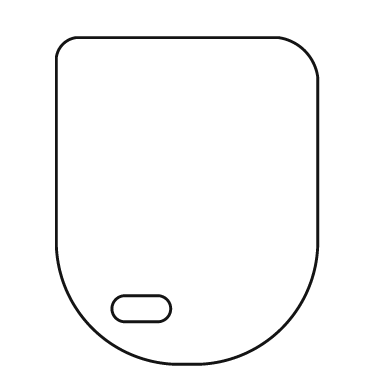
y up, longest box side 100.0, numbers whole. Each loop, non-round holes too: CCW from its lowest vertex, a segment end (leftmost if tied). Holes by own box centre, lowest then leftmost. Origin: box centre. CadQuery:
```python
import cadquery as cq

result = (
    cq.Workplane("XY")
    .moveTo(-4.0, -50.0)
    .lineTo(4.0, -50.0)
    .threePointArc((29.0, -39.0), (40.0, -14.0))
    .lineTo(40.0, 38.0)
    .threePointArc((36.0, 46.0), (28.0, 50.0))
    .lineTo(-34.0, 50.0)
    .threePointArc((-38.0, 48.0), (-40.0, 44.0))
    .lineTo(-40.0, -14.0)
    .threePointArc((-29.0, -39.0), (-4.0, -50.0))
    .close()
    .moveTo(-19.0, -37.0)
    .lineTo(-9.0, -37.0)
    .threePointArc((-5.0, -33.0), (-9.0, -29.0))
    .lineTo(-19.0, -29.0)
    .threePointArc((-23.0, -33.0), (-19.0, -37.0))
    .close()
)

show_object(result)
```